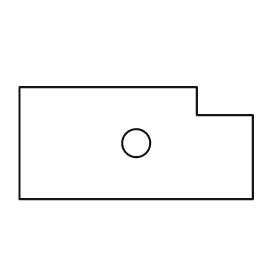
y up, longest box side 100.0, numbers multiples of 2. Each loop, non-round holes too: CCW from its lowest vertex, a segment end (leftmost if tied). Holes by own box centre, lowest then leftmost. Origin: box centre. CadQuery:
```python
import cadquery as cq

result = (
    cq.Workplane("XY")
    .moveTo(-50.0, -24.0)
    .lineTo(50.0, -24.0)
    .lineTo(50.0, 12.0)
    .lineTo(26.0, 12.0)
    .lineTo(26.0, 24.0)
    .lineTo(-50.0, 24.0)
    .close()
    .moveTo(0.0, 0.0)
    .circle(6.0)
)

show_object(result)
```